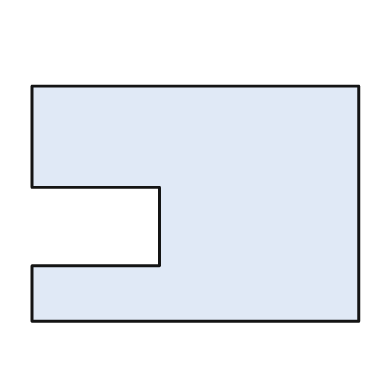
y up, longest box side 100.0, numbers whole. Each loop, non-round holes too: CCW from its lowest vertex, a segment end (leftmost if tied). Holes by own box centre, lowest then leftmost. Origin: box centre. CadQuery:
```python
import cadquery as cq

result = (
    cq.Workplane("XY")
    .moveTo(-50.0, -36.0)
    .lineTo(50.0, -36.0)
    .lineTo(50.0, 36.0)
    .lineTo(-50.0, 36.0)
    .lineTo(-50.0, 5.0)
    .lineTo(-11.0, 5.0)
    .lineTo(-11.0, -19.0)
    .lineTo(-50.0, -19.0)
    .close()
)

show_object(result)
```